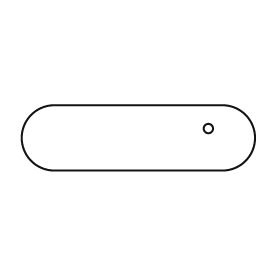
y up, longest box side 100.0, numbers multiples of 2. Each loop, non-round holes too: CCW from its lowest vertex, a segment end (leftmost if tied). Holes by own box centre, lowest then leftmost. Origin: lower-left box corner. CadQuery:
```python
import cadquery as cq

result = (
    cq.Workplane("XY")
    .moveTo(14.0, 0.0)
    .lineTo(86.0, 0.0)
    .threePointArc((100.0, 14.0), (86.0, 28.0))
    .lineTo(14.0, 28.0)
    .threePointArc((0.0, 14.0), (14.0, 0.0))
    .close()
    .moveTo(80.0, 18.0)
    .circle(2.0)
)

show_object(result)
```